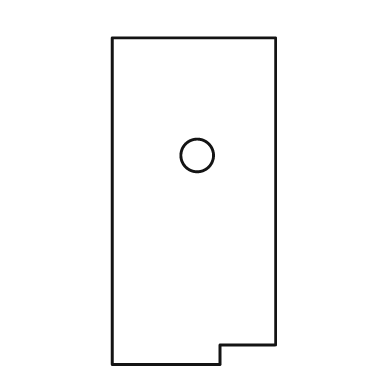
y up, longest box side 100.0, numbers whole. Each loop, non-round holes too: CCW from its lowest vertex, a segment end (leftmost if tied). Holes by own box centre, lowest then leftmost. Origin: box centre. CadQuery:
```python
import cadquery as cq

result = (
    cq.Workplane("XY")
    .moveTo(-25.0, -50.0)
    .lineTo(8.0, -50.0)
    .lineTo(8.0, -44.0)
    .lineTo(25.0, -44.0)
    .lineTo(25.0, 50.0)
    .lineTo(-25.0, 50.0)
    .close()
    .moveTo(1.0, 14.0)
    .circle(5.0)
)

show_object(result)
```